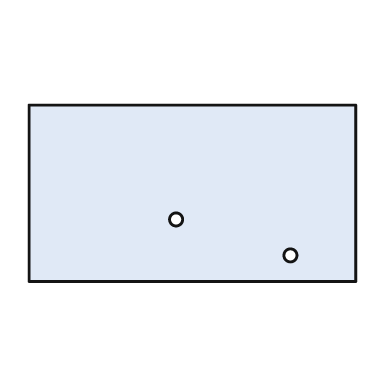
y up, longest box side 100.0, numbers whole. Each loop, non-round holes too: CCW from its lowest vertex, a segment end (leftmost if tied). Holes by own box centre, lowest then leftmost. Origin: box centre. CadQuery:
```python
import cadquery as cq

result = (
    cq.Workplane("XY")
    .moveTo(-50.0, -27.0)
    .lineTo(50.0, -27.0)
    .lineTo(50.0, 27.0)
    .lineTo(-50.0, 27.0)
    .close()
    .moveTo(30.0, -19.0)
    .circle(2.0)
    .moveTo(-5.0, -8.0)
    .circle(2.0)
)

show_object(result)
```